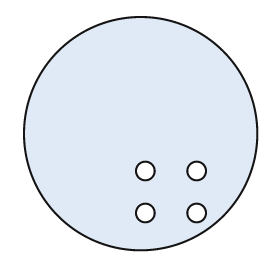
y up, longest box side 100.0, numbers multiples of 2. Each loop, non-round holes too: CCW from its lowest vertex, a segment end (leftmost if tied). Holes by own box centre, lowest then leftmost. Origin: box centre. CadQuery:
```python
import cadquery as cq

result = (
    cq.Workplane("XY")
    .moveTo(0.0, 0.0)
    .circle(50.0)
    .moveTo(2.0, -34.0)
    .circle(4.0)
    .moveTo(24.0, -34.0)
    .circle(4.0)
    .moveTo(2.0, -16.0)
    .circle(4.0)
    .moveTo(24.0, -16.0)
    .circle(4.0)
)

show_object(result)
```